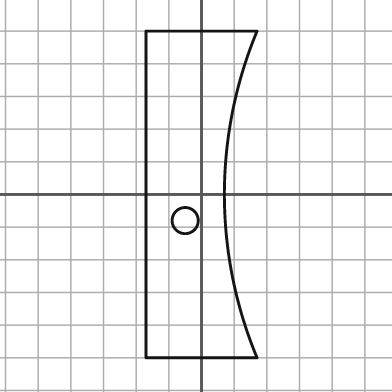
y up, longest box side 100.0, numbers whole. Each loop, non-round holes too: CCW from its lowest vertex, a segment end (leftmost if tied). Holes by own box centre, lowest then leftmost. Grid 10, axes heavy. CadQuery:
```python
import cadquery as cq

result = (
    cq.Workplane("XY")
    .moveTo(-17.0, -50.0)
    .lineTo(17.0, -50.0)
    .threePointArc((7.0, 0.0), (17.0, 50.0))
    .lineTo(-17.0, 50.0)
    .close()
    .moveTo(-5.0, -8.0)
    .circle(4.0)
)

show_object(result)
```